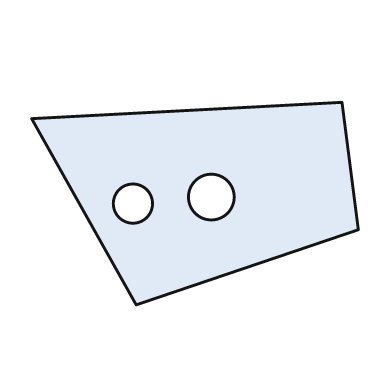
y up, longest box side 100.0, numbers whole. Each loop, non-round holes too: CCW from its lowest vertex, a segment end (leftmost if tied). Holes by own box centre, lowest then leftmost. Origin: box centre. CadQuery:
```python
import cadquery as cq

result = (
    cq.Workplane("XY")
    .moveTo(-18.0, -31.0)
    .lineTo(50.0, -8.0)
    .lineTo(45.0, 31.0)
    .lineTo(-50.0, 26.0)
    .close()
    .moveTo(-19.0, 0.0)
    .circle(6.0)
    .moveTo(5.0, 2.0)
    .circle(7.0)
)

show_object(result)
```